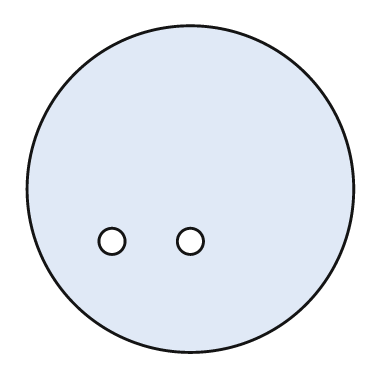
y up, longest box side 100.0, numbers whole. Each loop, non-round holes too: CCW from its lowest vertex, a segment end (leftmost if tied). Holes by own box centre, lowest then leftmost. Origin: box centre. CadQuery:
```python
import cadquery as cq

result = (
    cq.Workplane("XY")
    .moveTo(0.0, 0.0)
    .circle(50.0)
    .moveTo(-24.0, -16.0)
    .circle(4.0)
    .moveTo(0.0, -16.0)
    .circle(4.0)
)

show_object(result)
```